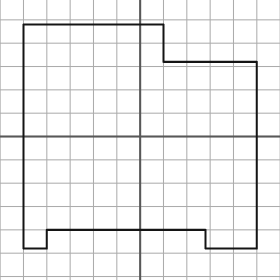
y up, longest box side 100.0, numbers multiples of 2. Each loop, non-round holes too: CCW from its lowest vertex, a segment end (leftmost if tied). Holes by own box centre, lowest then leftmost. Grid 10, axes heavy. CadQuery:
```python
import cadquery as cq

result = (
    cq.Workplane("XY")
    .moveTo(-50.0, -48.0)
    .lineTo(-40.0, -48.0)
    .lineTo(-40.0, -40.0)
    .lineTo(28.0, -40.0)
    .lineTo(28.0, -48.0)
    .lineTo(50.0, -48.0)
    .lineTo(50.0, 32.0)
    .lineTo(10.0, 32.0)
    .lineTo(10.0, 48.0)
    .lineTo(-50.0, 48.0)
    .close()
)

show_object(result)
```